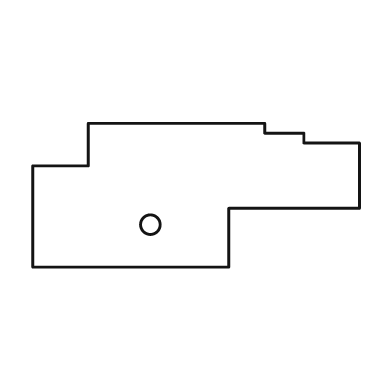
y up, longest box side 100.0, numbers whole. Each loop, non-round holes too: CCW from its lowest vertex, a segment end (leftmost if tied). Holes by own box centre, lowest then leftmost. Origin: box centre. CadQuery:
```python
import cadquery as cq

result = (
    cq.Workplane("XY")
    .moveTo(-50.0, -22.0)
    .lineTo(10.0, -22.0)
    .lineTo(10.0, -4.0)
    .lineTo(50.0, -4.0)
    .lineTo(50.0, 16.0)
    .lineTo(33.0, 16.0)
    .lineTo(33.0, 19.0)
    .lineTo(21.0, 19.0)
    .lineTo(21.0, 22.0)
    .lineTo(-33.0, 22.0)
    .lineTo(-33.0, 9.0)
    .lineTo(-50.0, 9.0)
    .close()
    .moveTo(-14.0, -9.0)
    .circle(3.0)
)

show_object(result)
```